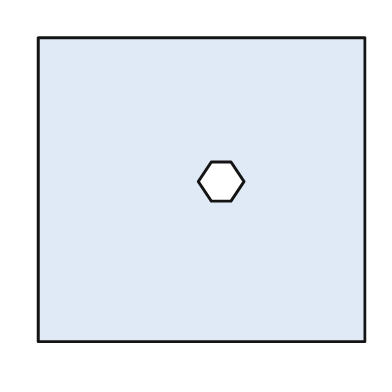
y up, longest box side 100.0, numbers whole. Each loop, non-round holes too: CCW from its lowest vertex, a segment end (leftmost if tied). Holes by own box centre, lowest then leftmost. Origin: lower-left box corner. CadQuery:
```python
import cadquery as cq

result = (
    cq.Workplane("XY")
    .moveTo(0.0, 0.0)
    .lineTo(100.0, 0.0)
    .lineTo(100.0, 93.0)
    .lineTo(0.0, 93.0)
    .close()
    .moveTo(53.0, 43.0)
    .lineTo(59.0, 43.0)
    .lineTo(63.0, 49.0)
    .lineTo(59.0, 55.0)
    .lineTo(53.0, 55.0)
    .lineTo(49.0, 49.0)
    .close()
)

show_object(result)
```